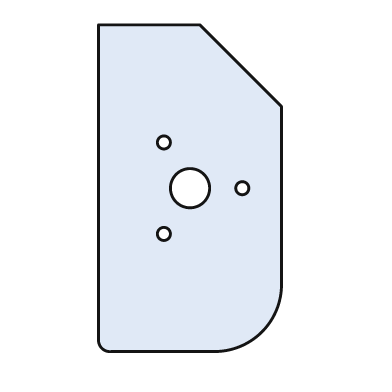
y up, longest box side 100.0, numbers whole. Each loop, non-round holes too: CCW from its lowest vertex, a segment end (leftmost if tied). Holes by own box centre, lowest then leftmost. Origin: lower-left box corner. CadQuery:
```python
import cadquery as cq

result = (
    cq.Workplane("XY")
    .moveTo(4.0, 0.0)
    .lineTo(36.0, 0.0)
    .threePointArc((50.0, 6.0), (56.0, 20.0))
    .lineTo(56.0, 75.0)
    .lineTo(31.0, 100.0)
    .lineTo(0.0, 100.0)
    .lineTo(0.0, 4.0)
    .threePointArc((1.0, 1.0), (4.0, 0.0))
    .close()
    .moveTo(20.0, 36.0)
    .circle(2.0)
    .moveTo(28.0, 50.0)
    .circle(6.0)
    .moveTo(44.0, 50.0)
    .circle(2.0)
    .moveTo(20.0, 64.0)
    .circle(2.0)
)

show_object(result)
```